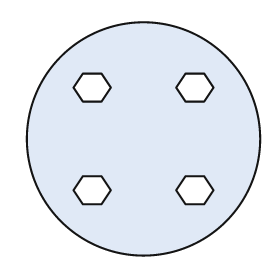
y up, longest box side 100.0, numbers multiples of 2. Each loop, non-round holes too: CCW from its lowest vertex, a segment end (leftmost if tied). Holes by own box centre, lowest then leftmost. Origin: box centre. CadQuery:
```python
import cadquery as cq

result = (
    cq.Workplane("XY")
    .moveTo(0.0, 0.0)
    .circle(50.0)
    .moveTo(-26.0, -28.0)
    .lineTo(-18.0, -28.0)
    .lineTo(-14.0, -22.0)
    .lineTo(-18.0, -16.0)
    .lineTo(-26.0, -16.0)
    .lineTo(-30.0, -22.0)
    .close()
    .moveTo(18.0, -28.0)
    .lineTo(26.0, -28.0)
    .lineTo(30.0, -22.0)
    .lineTo(26.0, -16.0)
    .lineTo(18.0, -16.0)
    .lineTo(14.0, -22.0)
    .close()
    .moveTo(-26.0, 16.0)
    .lineTo(-18.0, 16.0)
    .lineTo(-14.0, 22.0)
    .lineTo(-18.0, 28.0)
    .lineTo(-26.0, 28.0)
    .lineTo(-30.0, 22.0)
    .close()
    .moveTo(18.0, 16.0)
    .lineTo(26.0, 16.0)
    .lineTo(30.0, 22.0)
    .lineTo(26.0, 28.0)
    .lineTo(18.0, 28.0)
    .lineTo(14.0, 22.0)
    .close()
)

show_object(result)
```